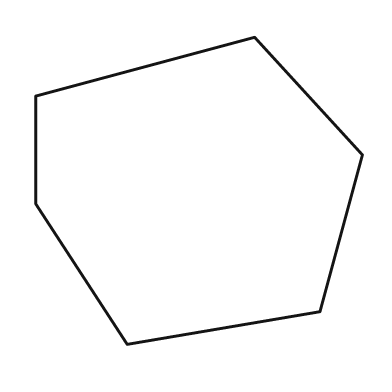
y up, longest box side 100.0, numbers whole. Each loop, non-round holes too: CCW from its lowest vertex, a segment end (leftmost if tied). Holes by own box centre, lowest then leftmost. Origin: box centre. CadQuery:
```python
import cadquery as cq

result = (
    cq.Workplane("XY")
    .moveTo(-22.0, -47.0)
    .lineTo(37.0, -37.0)
    .lineTo(50.0, 11.0)
    .lineTo(17.0, 47.0)
    .lineTo(-50.0, 29.0)
    .lineTo(-50.0, -4.0)
    .close()
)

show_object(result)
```